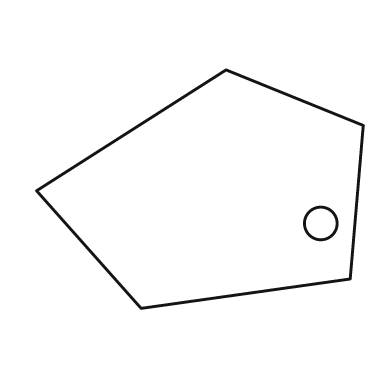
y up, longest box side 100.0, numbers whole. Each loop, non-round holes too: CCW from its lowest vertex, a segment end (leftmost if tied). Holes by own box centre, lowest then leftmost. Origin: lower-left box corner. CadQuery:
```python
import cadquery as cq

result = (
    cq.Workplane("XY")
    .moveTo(32.0, 0.0)
    .lineTo(96.0, 9.0)
    .lineTo(100.0, 56.0)
    .lineTo(58.0, 73.0)
    .lineTo(0.0, 36.0)
    .close()
    .moveTo(87.0, 26.0)
    .circle(5.0)
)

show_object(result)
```